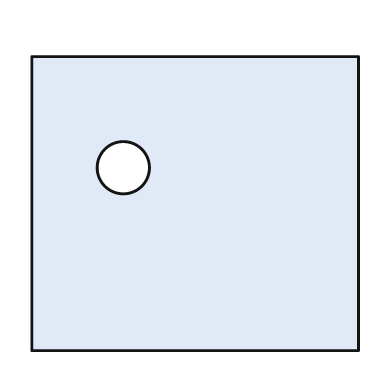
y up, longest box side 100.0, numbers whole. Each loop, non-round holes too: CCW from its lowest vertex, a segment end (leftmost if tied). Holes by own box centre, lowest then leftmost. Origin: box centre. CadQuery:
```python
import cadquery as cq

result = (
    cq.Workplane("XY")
    .moveTo(-50.0, -45.0)
    .lineTo(50.0, -45.0)
    .lineTo(50.0, 45.0)
    .lineTo(-50.0, 45.0)
    .close()
    .moveTo(-22.0, 11.0)
    .circle(8.0)
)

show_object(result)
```